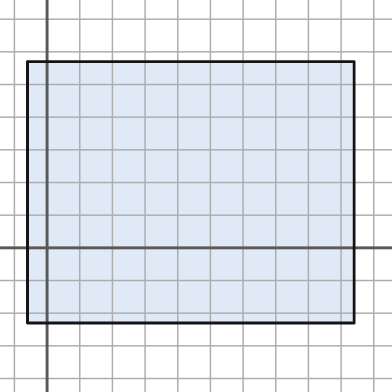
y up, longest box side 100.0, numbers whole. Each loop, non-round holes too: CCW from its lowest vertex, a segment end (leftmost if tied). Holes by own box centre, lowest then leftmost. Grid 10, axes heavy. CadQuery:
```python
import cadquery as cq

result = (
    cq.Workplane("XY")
    .moveTo(-6.0, -23.0)
    .lineTo(94.0, -23.0)
    .lineTo(94.0, 57.0)
    .lineTo(-6.0, 57.0)
    .close()
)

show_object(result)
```